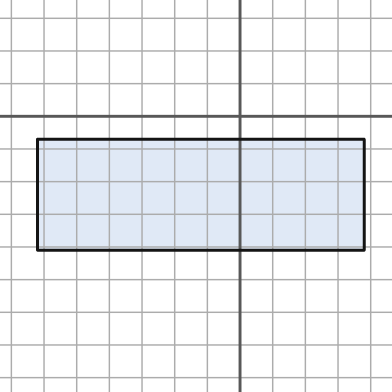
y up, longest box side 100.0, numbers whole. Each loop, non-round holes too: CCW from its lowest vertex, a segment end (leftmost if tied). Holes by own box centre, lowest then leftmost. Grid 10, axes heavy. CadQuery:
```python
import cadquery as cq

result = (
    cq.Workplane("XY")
    .moveTo(-62.0, -41.0)
    .lineTo(38.0, -41.0)
    .lineTo(38.0, -7.0)
    .lineTo(-62.0, -7.0)
    .close()
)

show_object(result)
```